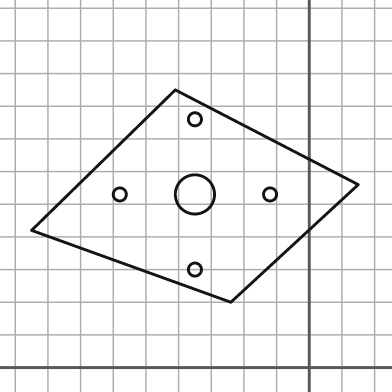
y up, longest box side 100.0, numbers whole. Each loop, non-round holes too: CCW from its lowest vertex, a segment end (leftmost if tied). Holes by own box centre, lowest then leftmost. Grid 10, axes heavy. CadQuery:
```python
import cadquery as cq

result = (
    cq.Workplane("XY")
    .moveTo(-24.0, 20.0)
    .lineTo(15.0, 56.0)
    .lineTo(-41.0, 85.0)
    .lineTo(-85.0, 42.0)
    .close()
    .moveTo(-35.0, 30.0)
    .circle(2.0)
    .moveTo(-58.0, 53.0)
    .circle(2.0)
    .moveTo(-35.0, 53.0)
    .circle(6.0)
    .moveTo(-12.0, 53.0)
    .circle(2.0)
    .moveTo(-35.0, 76.0)
    .circle(2.0)
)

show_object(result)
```